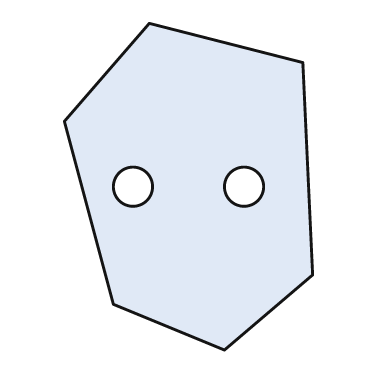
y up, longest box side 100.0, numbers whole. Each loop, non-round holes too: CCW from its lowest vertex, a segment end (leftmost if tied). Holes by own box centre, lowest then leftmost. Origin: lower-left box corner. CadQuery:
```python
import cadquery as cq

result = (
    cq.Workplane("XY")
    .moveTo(49.0, 0.0)
    .lineTo(76.0, 23.0)
    .lineTo(73.0, 88.0)
    .lineTo(26.0, 100.0)
    .lineTo(0.0, 70.0)
    .lineTo(15.0, 14.0)
    .close()
    .moveTo(21.0, 50.0)
    .circle(6.0)
    .moveTo(55.0, 50.0)
    .circle(6.0)
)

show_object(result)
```